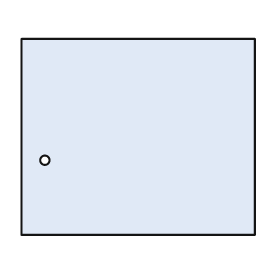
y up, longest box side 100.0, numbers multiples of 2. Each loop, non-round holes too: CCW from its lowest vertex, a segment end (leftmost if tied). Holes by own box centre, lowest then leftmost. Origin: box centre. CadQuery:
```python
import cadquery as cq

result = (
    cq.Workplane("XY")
    .moveTo(-50.0, -42.0)
    .lineTo(50.0, -42.0)
    .lineTo(50.0, 42.0)
    .lineTo(-50.0, 42.0)
    .close()
    .moveTo(-40.0, -10.0)
    .circle(2.0)
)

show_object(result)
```